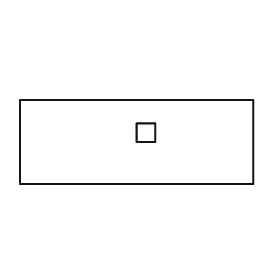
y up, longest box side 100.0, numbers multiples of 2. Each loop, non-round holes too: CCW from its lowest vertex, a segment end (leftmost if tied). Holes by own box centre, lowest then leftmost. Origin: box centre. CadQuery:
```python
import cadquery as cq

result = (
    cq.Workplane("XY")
    .moveTo(-50.0, -18.0)
    .lineTo(50.0, -18.0)
    .lineTo(50.0, 18.0)
    .lineTo(-50.0, 18.0)
    .close()
    .moveTo(0.0, 0.0)
    .lineTo(8.0, 0.0)
    .lineTo(8.0, 8.0)
    .lineTo(0.0, 8.0)
    .close()
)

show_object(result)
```